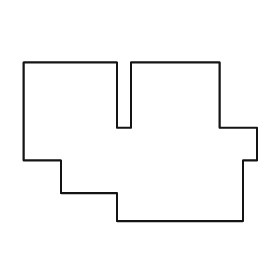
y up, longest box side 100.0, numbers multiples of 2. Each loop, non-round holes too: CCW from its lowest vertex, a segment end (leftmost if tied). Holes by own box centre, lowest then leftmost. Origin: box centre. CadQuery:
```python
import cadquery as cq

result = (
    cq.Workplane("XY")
    .moveTo(-10.0, -34.0)
    .lineTo(44.0, -34.0)
    .lineTo(44.0, -8.0)
    .lineTo(50.0, -8.0)
    .lineTo(50.0, 6.0)
    .lineTo(34.0, 6.0)
    .lineTo(34.0, 34.0)
    .lineTo(-4.0, 34.0)
    .lineTo(-4.0, 6.0)
    .lineTo(-10.0, 6.0)
    .lineTo(-10.0, 34.0)
    .lineTo(-50.0, 34.0)
    .lineTo(-50.0, -8.0)
    .lineTo(-34.0, -8.0)
    .lineTo(-34.0, -22.0)
    .lineTo(-10.0, -22.0)
    .close()
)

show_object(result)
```